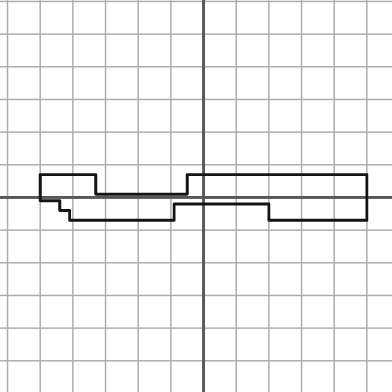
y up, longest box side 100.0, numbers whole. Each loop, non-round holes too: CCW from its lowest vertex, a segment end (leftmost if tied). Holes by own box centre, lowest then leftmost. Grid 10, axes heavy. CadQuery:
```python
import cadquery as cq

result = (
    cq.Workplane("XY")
    .moveTo(-41.0, -7.0)
    .lineTo(-9.0, -7.0)
    .lineTo(-9.0, -2.0)
    .lineTo(20.0, -2.0)
    .lineTo(20.0, -7.0)
    .lineTo(50.0, -7.0)
    .lineTo(50.0, 7.0)
    .lineTo(-5.0, 7.0)
    .lineTo(-5.0, 1.0)
    .lineTo(-33.0, 1.0)
    .lineTo(-33.0, 7.0)
    .lineTo(-50.0, 7.0)
    .lineTo(-50.0, -1.0)
    .lineTo(-44.0, -1.0)
    .lineTo(-44.0, -4.0)
    .lineTo(-41.0, -4.0)
    .close()
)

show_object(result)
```